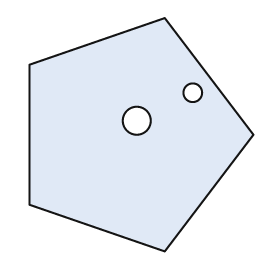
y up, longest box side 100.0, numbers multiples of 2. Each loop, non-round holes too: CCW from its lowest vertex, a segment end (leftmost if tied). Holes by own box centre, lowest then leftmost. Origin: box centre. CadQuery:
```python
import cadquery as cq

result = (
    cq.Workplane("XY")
    .moveTo(10.0, -50.0)
    .lineTo(48.0, 0.0)
    .lineTo(10.0, 50.0)
    .lineTo(-48.0, 30.0)
    .lineTo(-48.0, -30.0)
    .close()
    .moveTo(-2.0, 6.0)
    .circle(6.0)
    .moveTo(22.0, 18.0)
    .circle(4.0)
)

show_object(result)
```